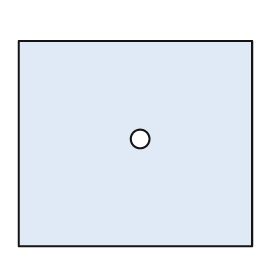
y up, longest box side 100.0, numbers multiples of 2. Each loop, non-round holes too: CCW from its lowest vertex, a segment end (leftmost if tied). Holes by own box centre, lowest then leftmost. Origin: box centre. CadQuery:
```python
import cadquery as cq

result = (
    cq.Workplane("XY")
    .moveTo(-50.0, -44.0)
    .lineTo(50.0, -44.0)
    .lineTo(50.0, 44.0)
    .lineTo(-50.0, 44.0)
    .close()
    .moveTo(2.0, 2.0)
    .circle(4.0)
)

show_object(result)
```